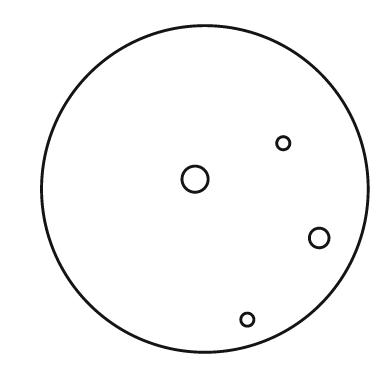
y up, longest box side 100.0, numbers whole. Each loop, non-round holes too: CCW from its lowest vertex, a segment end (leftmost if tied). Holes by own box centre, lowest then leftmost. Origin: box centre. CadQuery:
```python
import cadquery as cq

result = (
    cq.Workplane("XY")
    .moveTo(0.0, 0.0)
    .circle(50.0)
    .moveTo(13.0, -40.0)
    .circle(2.0)
    .moveTo(35.0, -15.0)
    .circle(3.0)
    .moveTo(-3.0, 3.0)
    .circle(4.0)
    .moveTo(24.0, 14.0)
    .circle(2.0)
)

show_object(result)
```